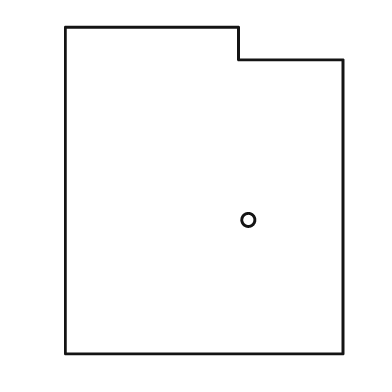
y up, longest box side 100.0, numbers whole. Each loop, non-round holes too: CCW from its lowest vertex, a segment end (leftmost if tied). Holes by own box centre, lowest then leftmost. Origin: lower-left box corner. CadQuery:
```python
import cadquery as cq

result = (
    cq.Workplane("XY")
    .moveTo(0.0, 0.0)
    .lineTo(85.0, 0.0)
    .lineTo(85.0, 90.0)
    .lineTo(53.0, 90.0)
    .lineTo(53.0, 100.0)
    .lineTo(0.0, 100.0)
    .close()
    .moveTo(56.0, 41.0)
    .circle(2.0)
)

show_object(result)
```